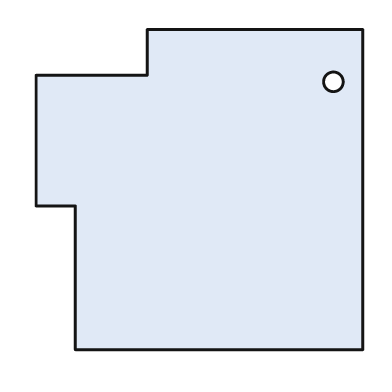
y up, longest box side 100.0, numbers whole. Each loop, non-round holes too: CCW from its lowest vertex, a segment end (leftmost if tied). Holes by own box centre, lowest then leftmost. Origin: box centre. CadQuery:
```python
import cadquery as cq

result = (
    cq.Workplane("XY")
    .moveTo(-38.0, -49.0)
    .lineTo(50.0, -49.0)
    .lineTo(50.0, 49.0)
    .lineTo(-16.0, 49.0)
    .lineTo(-16.0, 35.0)
    .lineTo(-50.0, 35.0)
    .lineTo(-50.0, -5.0)
    .lineTo(-38.0, -5.0)
    .close()
    .moveTo(41.0, 33.0)
    .circle(3.0)
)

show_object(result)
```